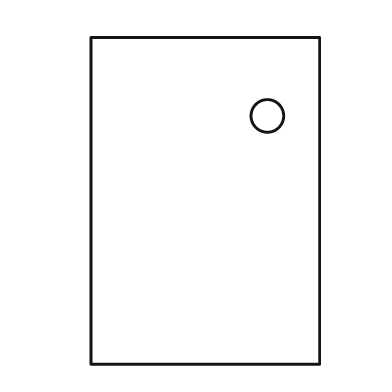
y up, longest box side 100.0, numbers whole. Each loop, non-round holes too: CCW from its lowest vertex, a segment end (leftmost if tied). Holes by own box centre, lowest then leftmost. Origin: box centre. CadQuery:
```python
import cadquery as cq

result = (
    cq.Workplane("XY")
    .moveTo(-35.0, -50.0)
    .lineTo(35.0, -50.0)
    .lineTo(35.0, 50.0)
    .lineTo(-35.0, 50.0)
    .close()
    .moveTo(19.0, 26.0)
    .circle(5.0)
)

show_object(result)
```